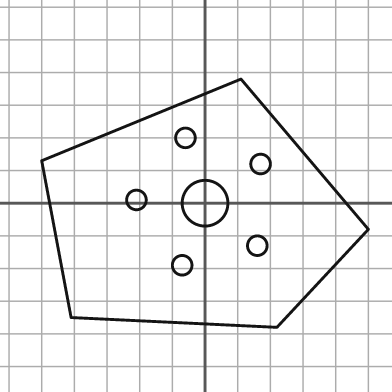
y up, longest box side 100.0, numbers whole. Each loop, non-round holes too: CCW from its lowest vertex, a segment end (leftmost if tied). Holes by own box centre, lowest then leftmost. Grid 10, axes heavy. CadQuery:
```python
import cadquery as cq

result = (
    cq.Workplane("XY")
    .moveTo(22.0, -38.0)
    .lineTo(50.0, -8.0)
    .lineTo(11.0, 38.0)
    .lineTo(-50.0, 13.0)
    .lineTo(-41.0, -35.0)
    .close()
    .moveTo(-7.0, -19.0)
    .circle(3.0)
    .moveTo(16.0, -13.0)
    .circle(3.0)
    .moveTo(0.0, 0.0)
    .circle(7.0)
    .moveTo(-21.0, 1.0)
    .circle(3.0)
    .moveTo(17.0, 12.0)
    .circle(3.0)
    .moveTo(-6.0, 20.0)
    .circle(3.0)
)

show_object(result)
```